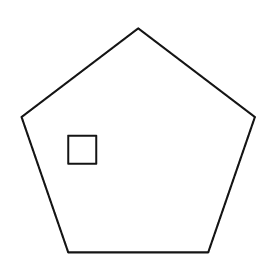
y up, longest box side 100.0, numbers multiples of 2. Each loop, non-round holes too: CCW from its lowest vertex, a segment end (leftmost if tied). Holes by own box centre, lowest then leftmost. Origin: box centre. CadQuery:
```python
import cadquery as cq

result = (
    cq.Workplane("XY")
    .moveTo(-30.0, -48.0)
    .lineTo(30.0, -48.0)
    .lineTo(50.0, 10.0)
    .lineTo(0.0, 48.0)
    .lineTo(-50.0, 10.0)
    .close()
    .moveTo(-30.0, -10.0)
    .lineTo(-18.0, -10.0)
    .lineTo(-18.0, 2.0)
    .lineTo(-30.0, 2.0)
    .close()
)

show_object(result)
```